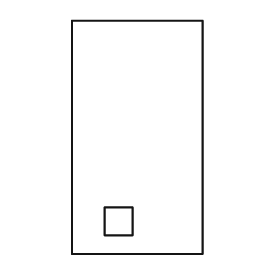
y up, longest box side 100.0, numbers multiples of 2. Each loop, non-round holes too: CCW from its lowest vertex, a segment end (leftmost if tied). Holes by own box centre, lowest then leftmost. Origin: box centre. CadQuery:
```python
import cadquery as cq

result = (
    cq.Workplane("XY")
    .moveTo(-28.0, -50.0)
    .lineTo(28.0, -50.0)
    .lineTo(28.0, 50.0)
    .lineTo(-28.0, 50.0)
    .close()
    .moveTo(-14.0, -42.0)
    .lineTo(-2.0, -42.0)
    .lineTo(-2.0, -30.0)
    .lineTo(-14.0, -30.0)
    .close()
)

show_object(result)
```